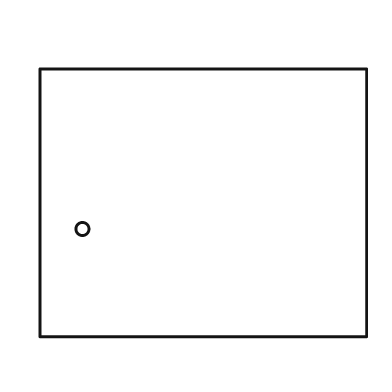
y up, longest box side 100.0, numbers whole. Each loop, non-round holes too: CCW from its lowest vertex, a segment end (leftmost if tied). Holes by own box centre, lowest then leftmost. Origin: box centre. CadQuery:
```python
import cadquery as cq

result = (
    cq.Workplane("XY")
    .moveTo(-50.0, -41.0)
    .lineTo(50.0, -41.0)
    .lineTo(50.0, 41.0)
    .lineTo(-50.0, 41.0)
    .close()
    .moveTo(-37.0, -8.0)
    .circle(2.0)
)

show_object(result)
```